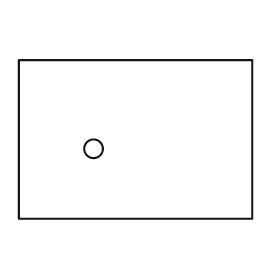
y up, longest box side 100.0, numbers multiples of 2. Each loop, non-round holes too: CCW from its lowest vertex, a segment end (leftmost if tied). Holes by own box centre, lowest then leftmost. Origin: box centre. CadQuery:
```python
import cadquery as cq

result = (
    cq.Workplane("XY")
    .moveTo(-50.0, -34.0)
    .lineTo(50.0, -34.0)
    .lineTo(50.0, 34.0)
    .lineTo(-50.0, 34.0)
    .close()
    .moveTo(-18.0, -4.0)
    .circle(4.0)
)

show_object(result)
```